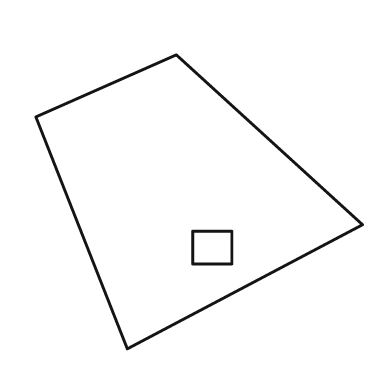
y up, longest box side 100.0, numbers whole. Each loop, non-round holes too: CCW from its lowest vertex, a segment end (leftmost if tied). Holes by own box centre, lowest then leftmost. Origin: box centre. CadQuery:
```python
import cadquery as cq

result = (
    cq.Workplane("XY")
    .moveTo(-22.0, -45.0)
    .lineTo(50.0, -7.0)
    .lineTo(-7.0, 45.0)
    .lineTo(-50.0, 26.0)
    .close()
    .moveTo(-2.0, -19.0)
    .lineTo(10.0, -19.0)
    .lineTo(10.0, -9.0)
    .lineTo(-2.0, -9.0)
    .close()
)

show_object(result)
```